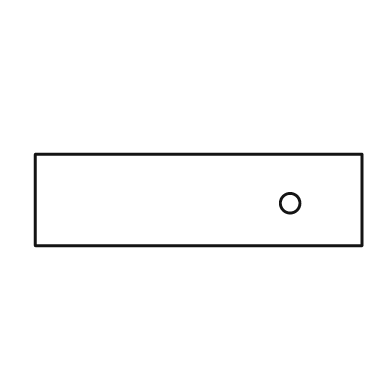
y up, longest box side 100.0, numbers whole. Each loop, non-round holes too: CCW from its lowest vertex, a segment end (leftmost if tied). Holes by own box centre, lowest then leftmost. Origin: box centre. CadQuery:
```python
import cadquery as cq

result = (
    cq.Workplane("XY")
    .moveTo(-50.0, -14.0)
    .lineTo(50.0, -14.0)
    .lineTo(50.0, 14.0)
    .lineTo(-50.0, 14.0)
    .close()
    .moveTo(28.0, -1.0)
    .circle(3.0)
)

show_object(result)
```